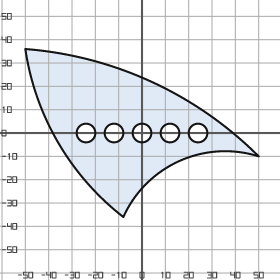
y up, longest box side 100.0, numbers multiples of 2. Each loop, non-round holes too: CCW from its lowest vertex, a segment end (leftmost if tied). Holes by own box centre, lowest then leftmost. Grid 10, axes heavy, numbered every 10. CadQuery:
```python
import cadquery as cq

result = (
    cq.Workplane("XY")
    .moveTo(-8.0, -36.0)
    .threePointArc((16.0, -12.0), (50.0, -10.0))
    .threePointArc((4.0, 22.0), (-50.0, 36.0))
    .threePointArc((-36.0, -4.0), (-8.0, -36.0))
    .close()
    .moveTo(-24.0, 0.0)
    .circle(4.0)
    .moveTo(-12.0, 0.0)
    .circle(4.0)
    .moveTo(0.0, 0.0)
    .circle(4.0)
    .moveTo(12.0, 0.0)
    .circle(4.0)
    .moveTo(24.0, 0.0)
    .circle(4.0)
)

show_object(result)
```